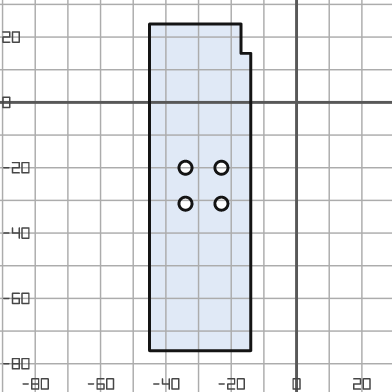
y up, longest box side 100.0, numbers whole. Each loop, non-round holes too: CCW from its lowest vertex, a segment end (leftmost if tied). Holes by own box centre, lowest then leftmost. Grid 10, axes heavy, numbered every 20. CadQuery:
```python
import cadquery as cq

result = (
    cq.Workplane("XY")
    .moveTo(-45.0, -76.0)
    .lineTo(-14.0, -76.0)
    .lineTo(-14.0, 15.0)
    .lineTo(-17.0, 15.0)
    .lineTo(-17.0, 24.0)
    .lineTo(-45.0, 24.0)
    .close()
    .moveTo(-34.0, -31.0)
    .circle(2.0)
    .moveTo(-23.0, -31.0)
    .circle(2.0)
    .moveTo(-34.0, -20.0)
    .circle(2.0)
    .moveTo(-23.0, -20.0)
    .circle(2.0)
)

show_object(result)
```